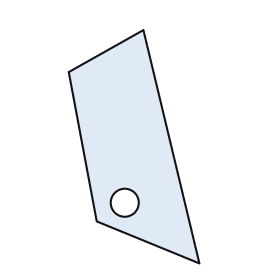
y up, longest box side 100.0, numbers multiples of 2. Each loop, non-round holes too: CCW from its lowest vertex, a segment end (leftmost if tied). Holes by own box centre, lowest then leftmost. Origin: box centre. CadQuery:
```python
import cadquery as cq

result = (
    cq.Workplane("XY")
    .moveTo(28.0, -50.0)
    .lineTo(4.0, 50.0)
    .lineTo(-28.0, 32.0)
    .lineTo(-16.0, -32.0)
    .close()
    .moveTo(-4.0, -24.0)
    .circle(6.0)
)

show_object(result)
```